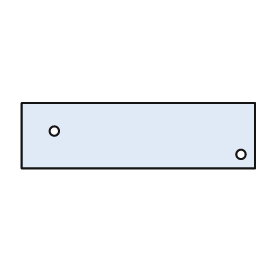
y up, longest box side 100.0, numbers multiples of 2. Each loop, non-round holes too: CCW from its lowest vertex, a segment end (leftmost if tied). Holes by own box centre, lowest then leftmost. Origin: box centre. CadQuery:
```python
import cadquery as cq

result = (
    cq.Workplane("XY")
    .moveTo(-50.0, -14.0)
    .lineTo(50.0, -14.0)
    .lineTo(50.0, 14.0)
    .lineTo(-50.0, 14.0)
    .close()
    .moveTo(44.0, -8.0)
    .circle(2.0)
    .moveTo(-36.0, 2.0)
    .circle(2.0)
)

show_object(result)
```